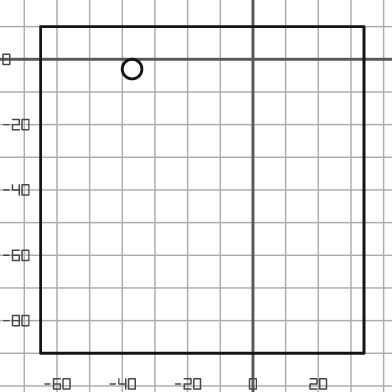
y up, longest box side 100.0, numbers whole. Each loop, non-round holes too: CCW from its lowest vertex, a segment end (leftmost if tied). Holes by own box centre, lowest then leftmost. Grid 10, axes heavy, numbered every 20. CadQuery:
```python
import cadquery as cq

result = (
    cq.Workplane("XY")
    .moveTo(-65.0, -90.0)
    .lineTo(34.0, -90.0)
    .lineTo(34.0, 10.0)
    .lineTo(-65.0, 10.0)
    .close()
    .moveTo(-37.0, -3.0)
    .circle(3.0)
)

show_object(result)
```